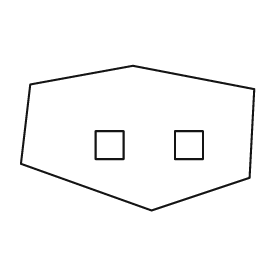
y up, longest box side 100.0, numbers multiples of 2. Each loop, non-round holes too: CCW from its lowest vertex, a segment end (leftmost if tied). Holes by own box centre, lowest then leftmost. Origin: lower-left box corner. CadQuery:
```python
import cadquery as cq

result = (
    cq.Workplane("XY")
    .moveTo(56.0, 0.0)
    .lineTo(98.0, 14.0)
    .lineTo(100.0, 52.0)
    .lineTo(48.0, 62.0)
    .lineTo(4.0, 54.0)
    .lineTo(0.0, 20.0)
    .close()
    .moveTo(32.0, 22.0)
    .lineTo(44.0, 22.0)
    .lineTo(44.0, 34.0)
    .lineTo(32.0, 34.0)
    .close()
    .moveTo(66.0, 22.0)
    .lineTo(78.0, 22.0)
    .lineTo(78.0, 34.0)
    .lineTo(66.0, 34.0)
    .close()
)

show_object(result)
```